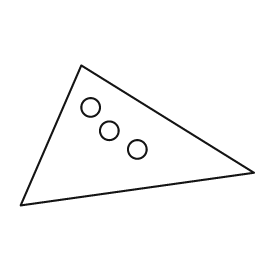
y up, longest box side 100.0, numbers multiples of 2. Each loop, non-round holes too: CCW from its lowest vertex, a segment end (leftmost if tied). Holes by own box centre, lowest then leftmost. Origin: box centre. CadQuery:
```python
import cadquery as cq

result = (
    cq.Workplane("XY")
    .moveTo(-50.0, -30.0)
    .lineTo(50.0, -16.0)
    .lineTo(-24.0, 30.0)
    .close()
    .moveTo(0.0, -6.0)
    .circle(4.0)
    .moveTo(-12.0, 2.0)
    .circle(4.0)
    .moveTo(-20.0, 12.0)
    .circle(4.0)
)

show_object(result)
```